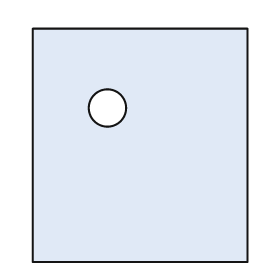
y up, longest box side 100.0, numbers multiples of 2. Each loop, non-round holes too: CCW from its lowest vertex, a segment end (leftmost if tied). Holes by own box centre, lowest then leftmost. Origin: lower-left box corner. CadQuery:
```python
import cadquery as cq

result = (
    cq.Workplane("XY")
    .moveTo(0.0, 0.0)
    .lineTo(92.0, 0.0)
    .lineTo(92.0, 100.0)
    .lineTo(0.0, 100.0)
    .close()
    .moveTo(32.0, 66.0)
    .circle(8.0)
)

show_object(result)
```